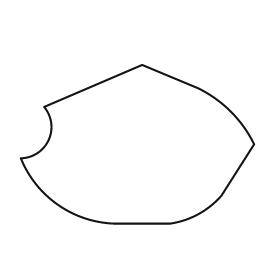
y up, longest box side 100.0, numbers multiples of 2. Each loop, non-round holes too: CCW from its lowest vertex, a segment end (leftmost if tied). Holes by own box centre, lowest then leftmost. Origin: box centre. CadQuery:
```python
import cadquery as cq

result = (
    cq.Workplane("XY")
    .moveTo(-10.0, -34.0)
    .lineTo(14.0, -34.0)
    .threePointArc((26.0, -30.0), (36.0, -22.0))
    .lineTo(50.0, 0.0)
    .threePointArc((40.0, 14.0), (26.0, 24.0))
    .lineTo(2.0, 34.0)
    .lineTo(-40.0, 16.0)
    .threePointArc((-38.0, 2.0), (-50.0, -6.0))
    .threePointArc((-34.0, -26.0), (-10.0, -34.0))
    .close()
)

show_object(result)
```